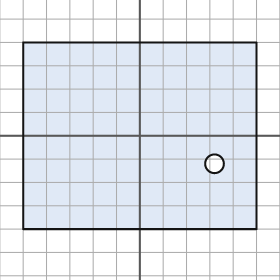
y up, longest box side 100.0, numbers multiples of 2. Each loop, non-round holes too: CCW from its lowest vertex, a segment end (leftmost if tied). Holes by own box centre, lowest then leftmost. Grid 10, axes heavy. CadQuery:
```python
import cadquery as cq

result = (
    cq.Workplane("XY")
    .moveTo(-50.0, -40.0)
    .lineTo(50.0, -40.0)
    .lineTo(50.0, 40.0)
    .lineTo(-50.0, 40.0)
    .close()
    .moveTo(32.0, -12.0)
    .circle(4.0)
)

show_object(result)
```